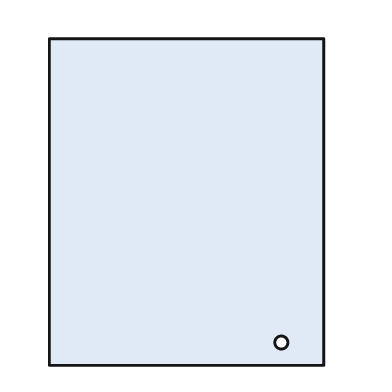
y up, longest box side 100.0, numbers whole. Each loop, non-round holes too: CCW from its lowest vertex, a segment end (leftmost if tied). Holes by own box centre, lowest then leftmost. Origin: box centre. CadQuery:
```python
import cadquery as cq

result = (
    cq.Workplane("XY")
    .moveTo(-42.0, -50.0)
    .lineTo(42.0, -50.0)
    .lineTo(42.0, 50.0)
    .lineTo(-42.0, 50.0)
    .close()
    .moveTo(29.0, -43.0)
    .circle(2.0)
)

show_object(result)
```